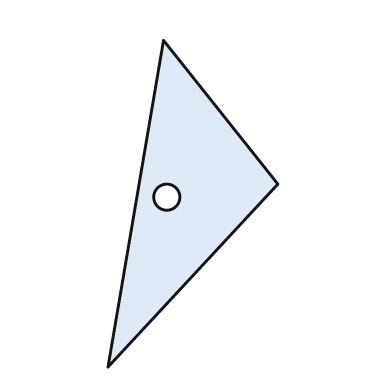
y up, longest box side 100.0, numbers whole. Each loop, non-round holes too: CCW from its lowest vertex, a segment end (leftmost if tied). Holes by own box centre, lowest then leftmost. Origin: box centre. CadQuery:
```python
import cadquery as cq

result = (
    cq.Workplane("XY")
    .moveTo(-26.0, -50.0)
    .lineTo(26.0, 6.0)
    .lineTo(-9.0, 50.0)
    .close()
    .moveTo(-8.0, 2.0)
    .circle(4.0)
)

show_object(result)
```